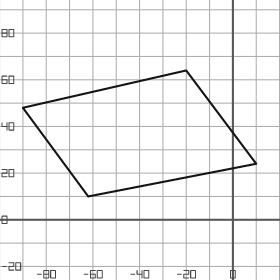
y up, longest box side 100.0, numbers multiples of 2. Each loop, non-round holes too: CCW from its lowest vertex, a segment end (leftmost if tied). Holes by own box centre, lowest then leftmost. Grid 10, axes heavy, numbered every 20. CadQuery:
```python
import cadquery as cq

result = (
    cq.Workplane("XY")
    .moveTo(-62.0, 10.0)
    .lineTo(10.0, 24.0)
    .lineTo(-20.0, 64.0)
    .lineTo(-90.0, 48.0)
    .close()
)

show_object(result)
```